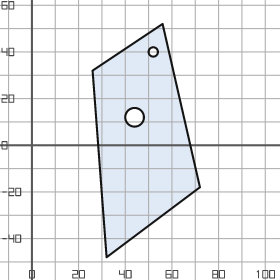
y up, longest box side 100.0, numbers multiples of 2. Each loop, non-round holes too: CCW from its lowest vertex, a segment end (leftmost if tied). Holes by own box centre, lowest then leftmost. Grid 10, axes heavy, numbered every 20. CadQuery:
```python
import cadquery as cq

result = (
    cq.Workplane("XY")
    .moveTo(32.0, -48.0)
    .lineTo(72.0, -18.0)
    .lineTo(56.0, 52.0)
    .lineTo(26.0, 32.0)
    .close()
    .moveTo(44.0, 12.0)
    .circle(4.0)
    .moveTo(52.0, 40.0)
    .circle(2.0)
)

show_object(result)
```